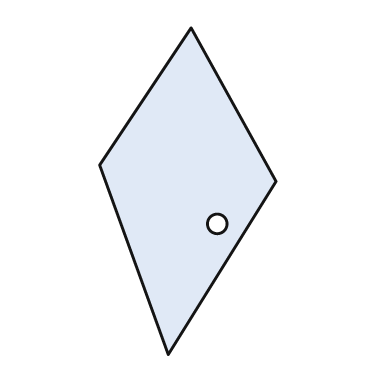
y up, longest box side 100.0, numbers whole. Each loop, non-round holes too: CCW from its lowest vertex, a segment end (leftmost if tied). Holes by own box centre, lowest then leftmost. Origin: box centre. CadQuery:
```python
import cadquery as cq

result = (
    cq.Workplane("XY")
    .moveTo(-6.0, -50.0)
    .lineTo(27.0, 3.0)
    .lineTo(1.0, 50.0)
    .lineTo(-27.0, 8.0)
    .close()
    .moveTo(9.0, -10.0)
    .circle(3.0)
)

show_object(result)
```